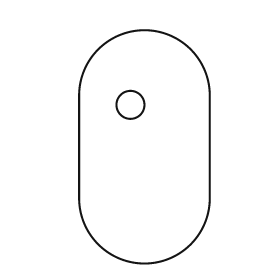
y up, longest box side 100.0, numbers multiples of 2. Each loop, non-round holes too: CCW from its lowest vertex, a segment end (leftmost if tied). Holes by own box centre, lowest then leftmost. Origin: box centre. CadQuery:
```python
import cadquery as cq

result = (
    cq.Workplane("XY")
    .moveTo(-28.0, -22.0)
    .threePointArc((0.0, -50.0), (28.0, -22.0))
    .lineTo(28.0, 22.0)
    .threePointArc((0.0, 50.0), (-28.0, 22.0))
    .close()
    .moveTo(-6.0, 18.0)
    .circle(6.0)
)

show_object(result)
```